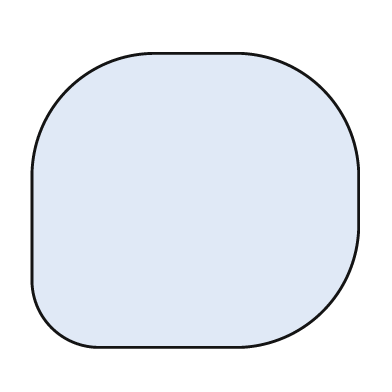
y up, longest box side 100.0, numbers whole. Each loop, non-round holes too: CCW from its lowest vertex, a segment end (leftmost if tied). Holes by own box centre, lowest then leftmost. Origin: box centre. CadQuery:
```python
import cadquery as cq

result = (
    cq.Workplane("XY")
    .moveTo(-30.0, -45.0)
    .lineTo(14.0, -45.0)
    .threePointArc((39.0, -34.0), (50.0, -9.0))
    .lineTo(50.0, 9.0)
    .threePointArc((39.0, 34.0), (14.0, 45.0))
    .lineTo(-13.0, 45.0)
    .threePointArc((-39.0, 34.0), (-50.0, 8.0))
    .lineTo(-50.0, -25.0)
    .threePointArc((-44.0, -39.0), (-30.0, -45.0))
    .close()
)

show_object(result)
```